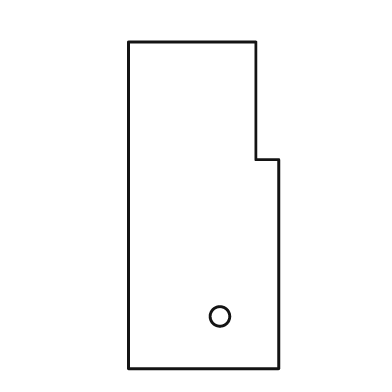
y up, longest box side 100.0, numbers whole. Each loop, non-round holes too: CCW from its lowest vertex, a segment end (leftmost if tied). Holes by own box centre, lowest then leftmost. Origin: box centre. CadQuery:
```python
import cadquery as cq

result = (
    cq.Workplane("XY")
    .moveTo(-23.0, -50.0)
    .lineTo(23.0, -50.0)
    .lineTo(23.0, 14.0)
    .lineTo(16.0, 14.0)
    .lineTo(16.0, 50.0)
    .lineTo(-23.0, 50.0)
    .close()
    .moveTo(5.0, -34.0)
    .circle(3.0)
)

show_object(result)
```